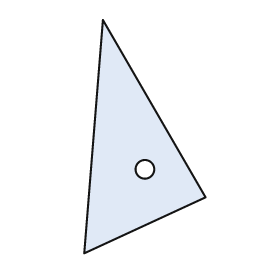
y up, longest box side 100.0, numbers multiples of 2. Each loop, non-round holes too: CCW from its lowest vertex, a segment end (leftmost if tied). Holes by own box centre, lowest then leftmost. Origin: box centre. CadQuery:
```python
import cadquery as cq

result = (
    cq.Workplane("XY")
    .moveTo(-26.0, -50.0)
    .lineTo(26.0, -26.0)
    .lineTo(-18.0, 50.0)
    .close()
    .moveTo(0.0, -14.0)
    .circle(4.0)
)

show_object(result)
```